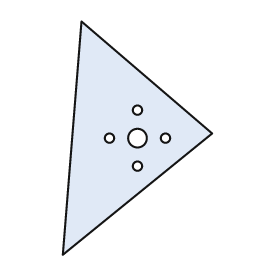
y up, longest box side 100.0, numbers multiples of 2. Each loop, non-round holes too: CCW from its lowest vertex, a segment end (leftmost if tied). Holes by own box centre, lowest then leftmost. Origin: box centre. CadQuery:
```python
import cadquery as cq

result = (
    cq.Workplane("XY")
    .moveTo(-32.0, -50.0)
    .lineTo(32.0, 2.0)
    .lineTo(-24.0, 50.0)
    .close()
    .moveTo(0.0, -12.0)
    .circle(2.0)
    .moveTo(-12.0, 0.0)
    .circle(2.0)
    .moveTo(0.0, 0.0)
    .circle(4.0)
    .moveTo(12.0, 0.0)
    .circle(2.0)
    .moveTo(0.0, 12.0)
    .circle(2.0)
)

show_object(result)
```